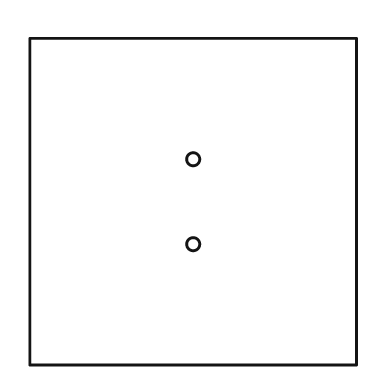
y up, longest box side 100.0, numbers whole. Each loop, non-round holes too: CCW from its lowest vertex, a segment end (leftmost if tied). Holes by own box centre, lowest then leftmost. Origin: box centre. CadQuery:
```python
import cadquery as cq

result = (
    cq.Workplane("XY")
    .moveTo(-50.0, -50.0)
    .lineTo(50.0, -50.0)
    .lineTo(50.0, 50.0)
    .lineTo(-50.0, 50.0)
    .close()
    .moveTo(0.0, -13.0)
    .circle(2.0)
    .moveTo(0.0, 13.0)
    .circle(2.0)
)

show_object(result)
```